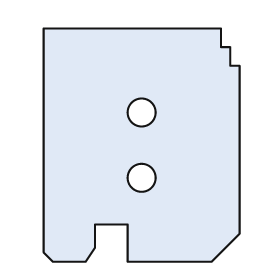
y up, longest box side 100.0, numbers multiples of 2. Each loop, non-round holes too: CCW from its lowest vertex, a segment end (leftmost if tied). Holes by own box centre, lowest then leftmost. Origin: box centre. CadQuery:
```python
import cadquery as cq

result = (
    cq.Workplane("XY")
    .moveTo(-38.0, -50.0)
    .lineTo(-24.0, -50.0)
    .lineTo(-20.0, -44.0)
    .lineTo(-20.0, -34.0)
    .lineTo(-6.0, -34.0)
    .lineTo(-6.0, -50.0)
    .lineTo(30.0, -50.0)
    .lineTo(42.0, -38.0)
    .lineTo(42.0, 34.0)
    .lineTo(38.0, 34.0)
    .lineTo(38.0, 42.0)
    .lineTo(34.0, 42.0)
    .lineTo(34.0, 50.0)
    .lineTo(-42.0, 50.0)
    .lineTo(-42.0, -46.0)
    .close()
    .moveTo(0.0, -14.0)
    .circle(6.0)
    .moveTo(0.0, 14.0)
    .circle(6.0)
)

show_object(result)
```